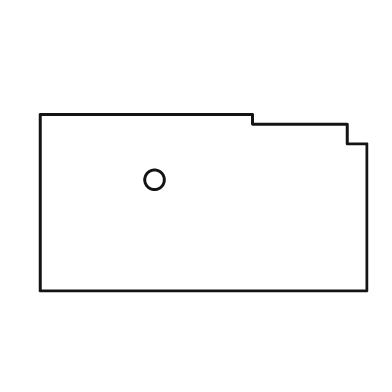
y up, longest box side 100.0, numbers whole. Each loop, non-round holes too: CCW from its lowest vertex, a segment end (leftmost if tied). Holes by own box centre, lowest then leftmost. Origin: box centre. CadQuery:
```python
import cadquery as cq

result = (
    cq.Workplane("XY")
    .moveTo(-50.0, -27.0)
    .lineTo(50.0, -27.0)
    .lineTo(50.0, 18.0)
    .lineTo(44.0, 18.0)
    .lineTo(44.0, 24.0)
    .lineTo(15.0, 24.0)
    .lineTo(15.0, 27.0)
    .lineTo(-50.0, 27.0)
    .close()
    .moveTo(-15.0, 7.0)
    .circle(3.0)
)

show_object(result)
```